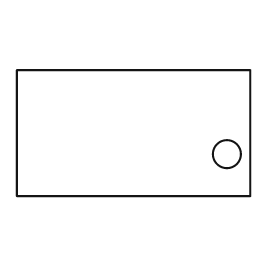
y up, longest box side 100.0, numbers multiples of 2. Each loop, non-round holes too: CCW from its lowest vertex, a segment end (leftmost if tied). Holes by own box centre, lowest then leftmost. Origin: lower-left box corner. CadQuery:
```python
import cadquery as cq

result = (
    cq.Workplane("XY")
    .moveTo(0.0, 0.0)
    .lineTo(100.0, 0.0)
    .lineTo(100.0, 54.0)
    .lineTo(0.0, 54.0)
    .close()
    .moveTo(90.0, 18.0)
    .circle(6.0)
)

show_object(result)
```